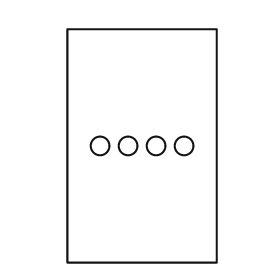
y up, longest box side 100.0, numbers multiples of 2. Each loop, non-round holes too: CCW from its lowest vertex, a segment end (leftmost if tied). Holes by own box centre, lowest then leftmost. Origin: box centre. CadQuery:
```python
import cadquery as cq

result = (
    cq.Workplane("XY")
    .moveTo(-32.0, -50.0)
    .lineTo(32.0, -50.0)
    .lineTo(32.0, 50.0)
    .lineTo(-32.0, 50.0)
    .close()
    .moveTo(-18.0, 0.0)
    .circle(4.0)
    .moveTo(-6.0, 0.0)
    .circle(4.0)
    .moveTo(6.0, 0.0)
    .circle(4.0)
    .moveTo(18.0, 0.0)
    .circle(4.0)
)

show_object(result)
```